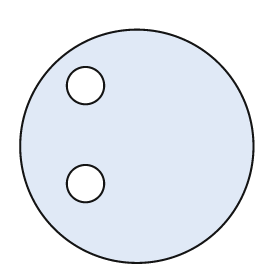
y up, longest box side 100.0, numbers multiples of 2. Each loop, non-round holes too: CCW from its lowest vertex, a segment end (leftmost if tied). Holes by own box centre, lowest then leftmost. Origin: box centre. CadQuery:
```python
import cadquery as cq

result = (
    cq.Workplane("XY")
    .moveTo(0.0, 0.0)
    .circle(50.0)
    .moveTo(-22.0, -16.0)
    .circle(8.0)
    .moveTo(-22.0, 26.0)
    .circle(8.0)
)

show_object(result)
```